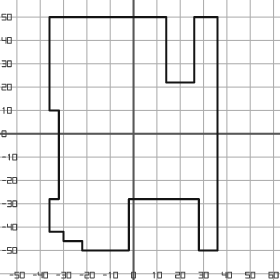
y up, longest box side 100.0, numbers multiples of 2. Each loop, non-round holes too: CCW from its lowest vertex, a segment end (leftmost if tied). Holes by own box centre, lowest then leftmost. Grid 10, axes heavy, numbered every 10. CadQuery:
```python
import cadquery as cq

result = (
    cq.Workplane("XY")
    .moveTo(-22.0, -50.0)
    .lineTo(-2.0, -50.0)
    .lineTo(-2.0, -28.0)
    .lineTo(28.0, -28.0)
    .lineTo(28.0, -50.0)
    .lineTo(36.0, -50.0)
    .lineTo(36.0, 50.0)
    .lineTo(26.0, 50.0)
    .lineTo(26.0, 22.0)
    .lineTo(14.0, 22.0)
    .lineTo(14.0, 50.0)
    .lineTo(-36.0, 50.0)
    .lineTo(-36.0, 10.0)
    .lineTo(-32.0, 10.0)
    .lineTo(-32.0, -28.0)
    .lineTo(-36.0, -28.0)
    .lineTo(-36.0, -42.0)
    .lineTo(-30.0, -42.0)
    .lineTo(-30.0, -46.0)
    .lineTo(-22.0, -46.0)
    .close()
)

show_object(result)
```